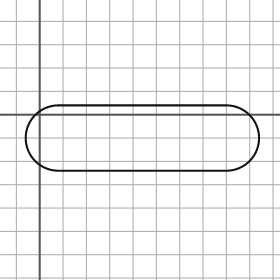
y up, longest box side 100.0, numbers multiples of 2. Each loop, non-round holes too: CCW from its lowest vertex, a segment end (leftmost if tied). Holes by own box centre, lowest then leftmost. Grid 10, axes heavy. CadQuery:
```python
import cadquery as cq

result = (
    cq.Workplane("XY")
    .moveTo(8.0, -24.0)
    .lineTo(80.0, -24.0)
    .threePointArc((94.0, -10.0), (80.0, 4.0))
    .lineTo(8.0, 4.0)
    .threePointArc((-6.0, -10.0), (8.0, -24.0))
    .close()
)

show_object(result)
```